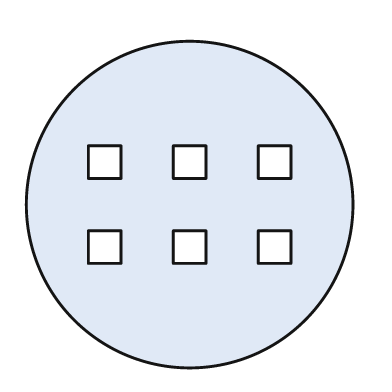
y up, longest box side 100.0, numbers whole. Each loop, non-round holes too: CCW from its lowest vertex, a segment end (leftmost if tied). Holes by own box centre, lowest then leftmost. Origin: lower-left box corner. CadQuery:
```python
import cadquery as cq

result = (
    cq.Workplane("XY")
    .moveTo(50.0, 50.0)
    .circle(50.0)
    .moveTo(19.0, 32.0)
    .lineTo(29.0, 32.0)
    .lineTo(29.0, 42.0)
    .lineTo(19.0, 42.0)
    .close()
    .moveTo(45.0, 32.0)
    .lineTo(55.0, 32.0)
    .lineTo(55.0, 42.0)
    .lineTo(45.0, 42.0)
    .close()
    .moveTo(71.0, 32.0)
    .lineTo(81.0, 32.0)
    .lineTo(81.0, 42.0)
    .lineTo(71.0, 42.0)
    .close()
    .moveTo(19.0, 58.0)
    .lineTo(29.0, 58.0)
    .lineTo(29.0, 68.0)
    .lineTo(19.0, 68.0)
    .close()
    .moveTo(45.0, 58.0)
    .lineTo(55.0, 58.0)
    .lineTo(55.0, 68.0)
    .lineTo(45.0, 68.0)
    .close()
    .moveTo(71.0, 58.0)
    .lineTo(81.0, 58.0)
    .lineTo(81.0, 68.0)
    .lineTo(71.0, 68.0)
    .close()
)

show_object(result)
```